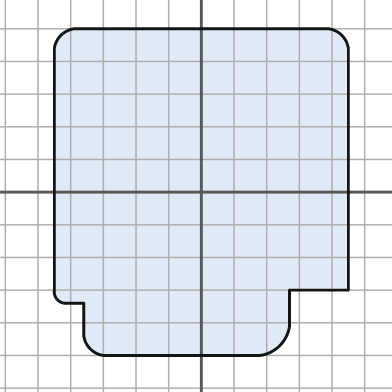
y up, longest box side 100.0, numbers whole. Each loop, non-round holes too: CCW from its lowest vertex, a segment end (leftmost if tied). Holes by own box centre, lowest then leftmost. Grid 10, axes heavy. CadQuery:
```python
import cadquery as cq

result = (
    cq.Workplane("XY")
    .moveTo(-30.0, -50.0)
    .lineTo(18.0, -50.0)
    .threePointArc((24.0, -47.0), (27.0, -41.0))
    .lineTo(27.0, -30.0)
    .lineTo(45.0, -30.0)
    .lineTo(45.0, 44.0)
    .threePointArc((43.0, 48.0), (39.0, 50.0))
    .lineTo(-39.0, 50.0)
    .threePointArc((-43.0, 48.0), (-45.0, 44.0))
    .lineTo(-45.0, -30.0)
    .threePointArc((-44.0, -33.0), (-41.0, -34.0))
    .lineTo(-36.0, -34.0)
    .lineTo(-36.0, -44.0)
    .threePointArc((-34.0, -48.0), (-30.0, -50.0))
    .close()
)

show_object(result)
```